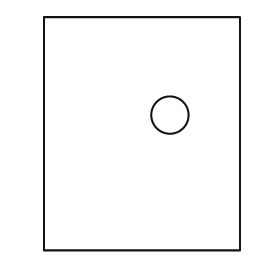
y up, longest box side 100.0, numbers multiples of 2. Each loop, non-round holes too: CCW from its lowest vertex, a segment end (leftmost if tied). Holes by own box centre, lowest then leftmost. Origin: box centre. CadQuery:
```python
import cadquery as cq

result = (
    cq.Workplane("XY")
    .moveTo(-42.0, -50.0)
    .lineTo(42.0, -50.0)
    .lineTo(42.0, 50.0)
    .lineTo(-42.0, 50.0)
    .close()
    .moveTo(12.0, 8.0)
    .circle(8.0)
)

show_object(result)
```